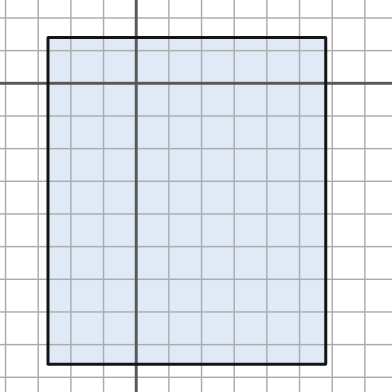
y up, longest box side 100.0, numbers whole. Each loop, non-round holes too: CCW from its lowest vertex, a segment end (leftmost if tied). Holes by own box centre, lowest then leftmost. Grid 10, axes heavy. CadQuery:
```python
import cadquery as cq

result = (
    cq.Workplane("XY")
    .moveTo(-27.0, -86.0)
    .lineTo(58.0, -86.0)
    .lineTo(58.0, 14.0)
    .lineTo(-27.0, 14.0)
    .close()
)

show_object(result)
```